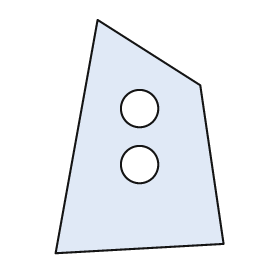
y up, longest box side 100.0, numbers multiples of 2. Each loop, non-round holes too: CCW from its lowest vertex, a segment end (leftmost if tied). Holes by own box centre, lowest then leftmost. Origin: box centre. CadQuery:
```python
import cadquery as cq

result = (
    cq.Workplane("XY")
    .moveTo(-36.0, -50.0)
    .lineTo(36.0, -46.0)
    .lineTo(26.0, 22.0)
    .lineTo(-18.0, 50.0)
    .close()
    .moveTo(0.0, -12.0)
    .circle(8.0)
    .moveTo(0.0, 12.0)
    .circle(8.0)
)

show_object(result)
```